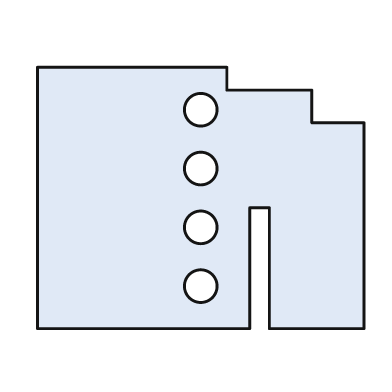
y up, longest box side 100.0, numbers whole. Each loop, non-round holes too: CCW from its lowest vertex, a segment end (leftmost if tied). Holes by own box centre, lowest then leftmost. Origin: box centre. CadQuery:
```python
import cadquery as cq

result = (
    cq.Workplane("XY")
    .moveTo(-50.0, -40.0)
    .lineTo(15.0, -40.0)
    .lineTo(15.0, -3.0)
    .lineTo(21.0, -3.0)
    .lineTo(21.0, -40.0)
    .lineTo(50.0, -40.0)
    .lineTo(50.0, 23.0)
    .lineTo(34.0, 23.0)
    .lineTo(34.0, 33.0)
    .lineTo(8.0, 33.0)
    .lineTo(8.0, 40.0)
    .lineTo(-50.0, 40.0)
    .close()
    .moveTo(0.0, -27.0)
    .circle(5.0)
    .moveTo(0.0, -9.0)
    .circle(5.0)
    .moveTo(0.0, 9.0)
    .circle(5.0)
    .moveTo(0.0, 27.0)
    .circle(5.0)
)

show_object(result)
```